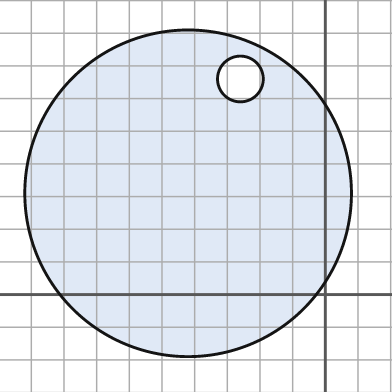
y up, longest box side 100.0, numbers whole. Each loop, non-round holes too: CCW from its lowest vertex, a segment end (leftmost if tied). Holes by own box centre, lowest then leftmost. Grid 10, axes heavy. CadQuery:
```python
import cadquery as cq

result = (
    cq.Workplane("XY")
    .moveTo(-42.0, 31.0)
    .circle(50.0)
    .moveTo(-26.0, 66.0)
    .circle(7.0)
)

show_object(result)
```